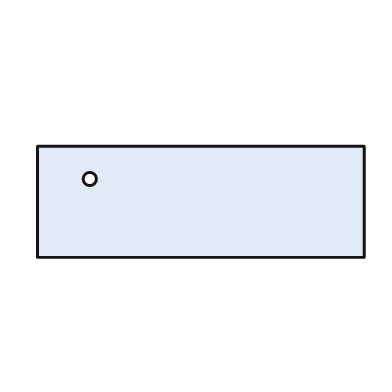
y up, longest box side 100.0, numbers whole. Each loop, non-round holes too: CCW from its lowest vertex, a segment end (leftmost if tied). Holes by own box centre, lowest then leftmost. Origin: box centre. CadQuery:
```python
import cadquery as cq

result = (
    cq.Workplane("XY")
    .moveTo(-50.0, -17.0)
    .lineTo(50.0, -17.0)
    .lineTo(50.0, 17.0)
    .lineTo(-50.0, 17.0)
    .close()
    .moveTo(-34.0, 7.0)
    .circle(2.0)
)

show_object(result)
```